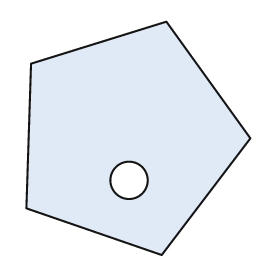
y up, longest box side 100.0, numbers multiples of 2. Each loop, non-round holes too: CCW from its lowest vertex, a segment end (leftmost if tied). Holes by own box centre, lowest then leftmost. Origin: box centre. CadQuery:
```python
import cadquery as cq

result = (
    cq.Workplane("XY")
    .moveTo(10.0, -50.0)
    .lineTo(48.0, 0.0)
    .lineTo(12.0, 50.0)
    .lineTo(-46.0, 32.0)
    .lineTo(-48.0, -30.0)
    .close()
    .moveTo(-4.0, -18.0)
    .circle(8.0)
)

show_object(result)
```